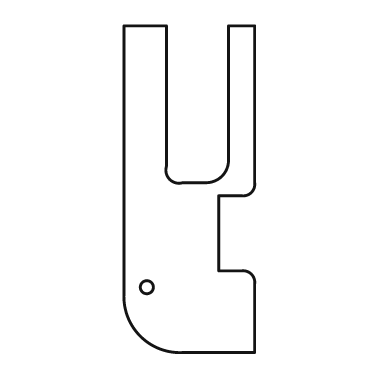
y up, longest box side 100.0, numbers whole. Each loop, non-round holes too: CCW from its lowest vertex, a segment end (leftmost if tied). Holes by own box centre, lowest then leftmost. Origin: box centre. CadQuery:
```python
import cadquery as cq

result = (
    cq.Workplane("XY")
    .moveTo(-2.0, -50.0)
    .lineTo(20.0, -50.0)
    .lineTo(20.0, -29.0)
    .threePointArc((19.0, -26.0), (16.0, -25.0))
    .lineTo(9.0, -25.0)
    .lineTo(9.0, -2.0)
    .lineTo(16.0, -2.0)
    .threePointArc((19.0, -1.0), (20.0, 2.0))
    .lineTo(20.0, 50.0)
    .lineTo(12.0, 50.0)
    .lineTo(12.0, 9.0)
    .threePointArc((10.0, 4.0), (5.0, 2.0))
    .lineTo(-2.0, 2.0)
    .threePointArc((-6.0, 3.0), (-7.0, 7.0))
    .lineTo(-7.0, 50.0)
    .lineTo(-20.0, 50.0)
    .lineTo(-20.0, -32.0)
    .threePointArc((-15.0, -45.0), (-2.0, -50.0))
    .close()
    .moveTo(-13.0, -30.0)
    .circle(2.0)
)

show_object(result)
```